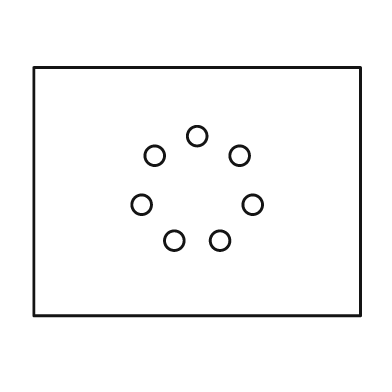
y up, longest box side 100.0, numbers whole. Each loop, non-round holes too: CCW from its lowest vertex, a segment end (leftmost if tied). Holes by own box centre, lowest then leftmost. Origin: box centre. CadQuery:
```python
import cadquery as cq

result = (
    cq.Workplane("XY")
    .moveTo(-50.0, -38.0)
    .lineTo(50.0, -38.0)
    .lineTo(50.0, 38.0)
    .lineTo(-50.0, 38.0)
    .close()
    .moveTo(-7.0, -15.0)
    .circle(3.0)
    .moveTo(7.0, -15.0)
    .circle(3.0)
    .moveTo(-17.0, -4.0)
    .circle(3.0)
    .moveTo(17.0, -4.0)
    .circle(3.0)
    .moveTo(-13.0, 11.0)
    .circle(3.0)
    .moveTo(13.0, 11.0)
    .circle(3.0)
    .moveTo(0.0, 17.0)
    .circle(3.0)
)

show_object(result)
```